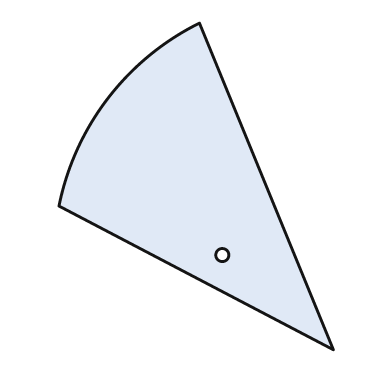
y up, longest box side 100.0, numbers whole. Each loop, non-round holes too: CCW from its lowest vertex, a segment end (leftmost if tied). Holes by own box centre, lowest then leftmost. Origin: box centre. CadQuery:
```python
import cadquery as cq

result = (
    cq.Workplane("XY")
    .moveTo(42.0, -50.0)
    .lineTo(1.0, 50.0)
    .threePointArc((-27.0, 27.0), (-42.0, -6.0))
    .close()
    .moveTo(8.0, -21.0)
    .circle(2.0)
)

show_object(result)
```